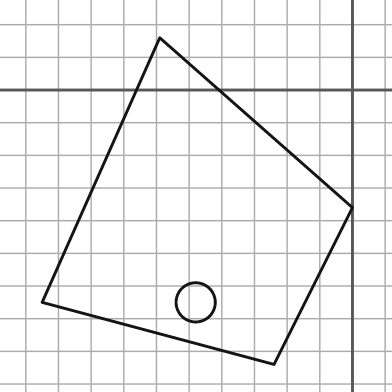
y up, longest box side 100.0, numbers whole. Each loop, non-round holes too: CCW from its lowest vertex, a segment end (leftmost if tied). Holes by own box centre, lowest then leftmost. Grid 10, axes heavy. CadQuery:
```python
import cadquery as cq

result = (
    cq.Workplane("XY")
    .moveTo(-24.0, -84.0)
    .lineTo(0.0, -36.0)
    .lineTo(-59.0, 16.0)
    .lineTo(-95.0, -65.0)
    .close()
    .moveTo(-48.0, -65.0)
    .circle(6.0)
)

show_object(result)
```